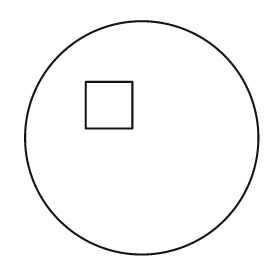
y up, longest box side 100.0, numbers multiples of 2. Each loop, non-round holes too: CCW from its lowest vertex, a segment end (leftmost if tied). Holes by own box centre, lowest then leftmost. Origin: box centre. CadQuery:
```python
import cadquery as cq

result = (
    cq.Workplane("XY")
    .moveTo(0.0, 0.0)
    .circle(50.0)
    .moveTo(-24.0, 4.0)
    .lineTo(-4.0, 4.0)
    .lineTo(-4.0, 24.0)
    .lineTo(-24.0, 24.0)
    .close()
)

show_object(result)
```